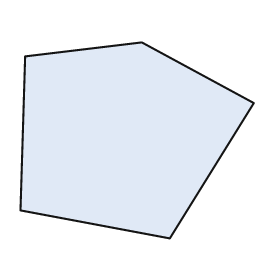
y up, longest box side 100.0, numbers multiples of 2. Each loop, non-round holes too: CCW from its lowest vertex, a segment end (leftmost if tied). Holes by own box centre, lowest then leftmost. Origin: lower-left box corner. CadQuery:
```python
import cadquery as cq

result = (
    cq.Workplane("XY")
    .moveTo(64.0, 0.0)
    .lineTo(100.0, 58.0)
    .lineTo(52.0, 84.0)
    .lineTo(2.0, 78.0)
    .lineTo(0.0, 12.0)
    .close()
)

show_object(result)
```